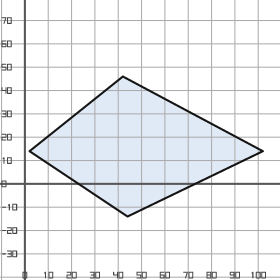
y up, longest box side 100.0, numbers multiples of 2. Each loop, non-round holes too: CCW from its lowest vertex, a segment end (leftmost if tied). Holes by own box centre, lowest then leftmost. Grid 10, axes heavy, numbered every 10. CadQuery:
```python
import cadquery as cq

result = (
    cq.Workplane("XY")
    .moveTo(44.0, -14.0)
    .lineTo(102.0, 14.0)
    .lineTo(42.0, 46.0)
    .lineTo(2.0, 14.0)
    .close()
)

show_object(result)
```